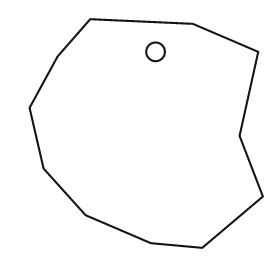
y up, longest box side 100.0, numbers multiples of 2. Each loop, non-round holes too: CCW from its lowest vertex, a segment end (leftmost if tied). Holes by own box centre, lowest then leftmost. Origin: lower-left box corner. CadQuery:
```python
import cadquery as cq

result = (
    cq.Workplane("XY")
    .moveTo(74.0, 0.0)
    .lineTo(100.0, 22.0)
    .lineTo(90.0, 48.0)
    .lineTo(98.0, 84.0)
    .lineTo(70.0, 96.0)
    .lineTo(26.0, 98.0)
    .lineTo(12.0, 82.0)
    .lineTo(0.0, 60.0)
    .lineTo(6.0, 34.0)
    .lineTo(24.0, 14.0)
    .lineTo(52.0, 2.0)
    .close()
    .moveTo(54.0, 84.0)
    .circle(4.0)
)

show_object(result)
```